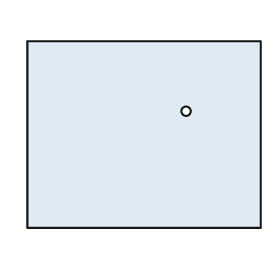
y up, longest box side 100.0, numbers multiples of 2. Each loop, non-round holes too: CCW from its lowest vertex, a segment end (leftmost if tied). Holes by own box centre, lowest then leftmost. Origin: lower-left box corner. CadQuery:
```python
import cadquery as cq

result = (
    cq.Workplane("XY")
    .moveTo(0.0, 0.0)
    .lineTo(100.0, 0.0)
    .lineTo(100.0, 80.0)
    .lineTo(0.0, 80.0)
    .close()
    .moveTo(68.0, 50.0)
    .circle(2.0)
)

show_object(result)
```